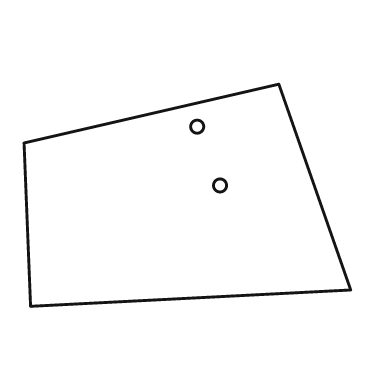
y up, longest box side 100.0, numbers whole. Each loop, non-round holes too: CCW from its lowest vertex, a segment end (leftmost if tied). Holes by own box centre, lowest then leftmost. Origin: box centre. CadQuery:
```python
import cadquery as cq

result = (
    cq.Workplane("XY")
    .moveTo(-48.0, -34.0)
    .lineTo(50.0, -29.0)
    .lineTo(28.0, 34.0)
    .lineTo(-50.0, 16.0)
    .close()
    .moveTo(10.0, 3.0)
    .circle(2.0)
    .moveTo(3.0, 21.0)
    .circle(2.0)
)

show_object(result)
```